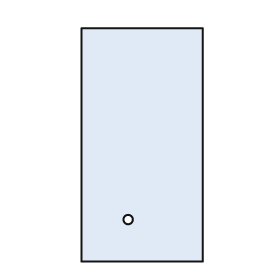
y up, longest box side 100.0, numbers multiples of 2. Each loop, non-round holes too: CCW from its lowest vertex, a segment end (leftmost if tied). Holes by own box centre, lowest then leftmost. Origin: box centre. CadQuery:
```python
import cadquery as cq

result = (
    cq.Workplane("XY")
    .moveTo(-26.0, -50.0)
    .lineTo(26.0, -50.0)
    .lineTo(26.0, 50.0)
    .lineTo(-26.0, 50.0)
    .close()
    .moveTo(-6.0, -32.0)
    .circle(2.0)
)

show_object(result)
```